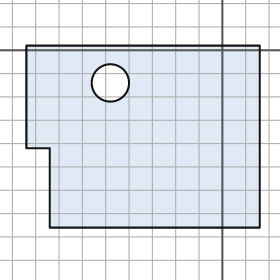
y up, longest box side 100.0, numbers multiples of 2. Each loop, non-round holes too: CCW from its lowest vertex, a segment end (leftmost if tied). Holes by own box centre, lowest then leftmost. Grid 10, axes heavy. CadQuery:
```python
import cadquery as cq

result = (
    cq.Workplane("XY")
    .moveTo(-74.0, -76.0)
    .lineTo(16.0, -76.0)
    .lineTo(16.0, 2.0)
    .lineTo(-84.0, 2.0)
    .lineTo(-84.0, -42.0)
    .lineTo(-74.0, -42.0)
    .close()
    .moveTo(-48.0, -14.0)
    .circle(8.0)
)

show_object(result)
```